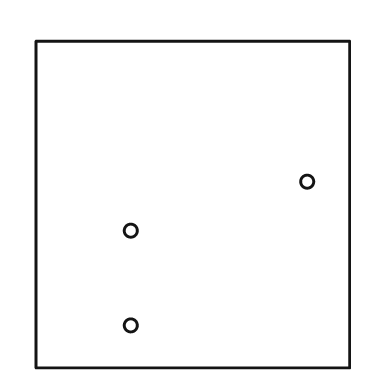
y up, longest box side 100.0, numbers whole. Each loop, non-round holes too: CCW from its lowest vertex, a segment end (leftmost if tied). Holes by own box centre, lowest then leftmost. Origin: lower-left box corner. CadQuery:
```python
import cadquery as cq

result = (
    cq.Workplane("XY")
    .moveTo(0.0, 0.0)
    .lineTo(96.0, 0.0)
    .lineTo(96.0, 100.0)
    .lineTo(0.0, 100.0)
    .close()
    .moveTo(29.0, 13.0)
    .circle(2.0)
    .moveTo(29.0, 42.0)
    .circle(2.0)
    .moveTo(83.0, 57.0)
    .circle(2.0)
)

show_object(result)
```